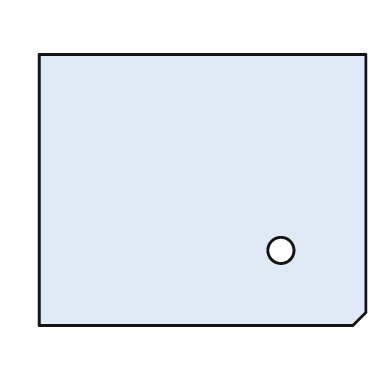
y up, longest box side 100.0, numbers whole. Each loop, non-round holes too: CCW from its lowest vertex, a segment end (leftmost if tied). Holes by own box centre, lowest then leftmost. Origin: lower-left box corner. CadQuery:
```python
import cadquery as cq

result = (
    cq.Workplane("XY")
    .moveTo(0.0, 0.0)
    .lineTo(96.0, 0.0)
    .lineTo(100.0, 4.0)
    .lineTo(100.0, 83.0)
    .lineTo(0.0, 83.0)
    .close()
    .moveTo(74.0, 23.0)
    .circle(4.0)
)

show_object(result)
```